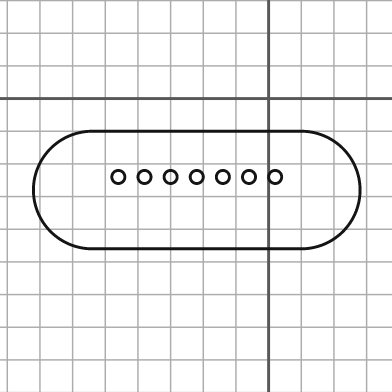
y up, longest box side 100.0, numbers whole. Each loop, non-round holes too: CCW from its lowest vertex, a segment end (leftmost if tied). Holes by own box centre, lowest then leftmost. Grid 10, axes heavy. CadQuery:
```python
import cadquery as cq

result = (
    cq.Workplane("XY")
    .moveTo(-54.0, -46.0)
    .lineTo(10.0, -46.0)
    .threePointArc((28.0, -28.0), (10.0, -10.0))
    .lineTo(-54.0, -10.0)
    .threePointArc((-72.0, -28.0), (-54.0, -46.0))
    .close()
    .moveTo(-46.0, -24.0)
    .circle(2.0)
    .moveTo(-38.0, -24.0)
    .circle(2.0)
    .moveTo(-30.0, -24.0)
    .circle(2.0)
    .moveTo(-22.0, -24.0)
    .circle(2.0)
    .moveTo(-14.0, -24.0)
    .circle(2.0)
    .moveTo(-6.0, -24.0)
    .circle(2.0)
    .moveTo(2.0, -24.0)
    .circle(2.0)
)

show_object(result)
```